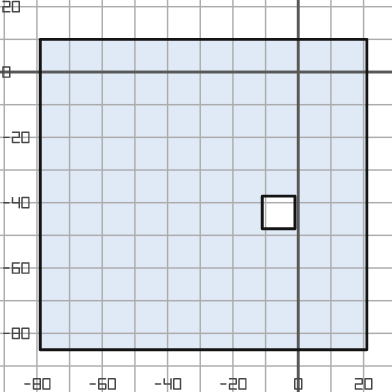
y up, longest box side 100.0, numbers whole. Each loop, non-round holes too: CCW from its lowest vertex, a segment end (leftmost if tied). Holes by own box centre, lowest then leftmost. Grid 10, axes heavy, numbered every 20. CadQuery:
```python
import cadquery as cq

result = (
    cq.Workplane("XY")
    .moveTo(-79.0, -85.0)
    .lineTo(21.0, -85.0)
    .lineTo(21.0, 10.0)
    .lineTo(-79.0, 10.0)
    .close()
    .moveTo(-11.0, -48.0)
    .lineTo(-1.0, -48.0)
    .lineTo(-1.0, -38.0)
    .lineTo(-11.0, -38.0)
    .close()
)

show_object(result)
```